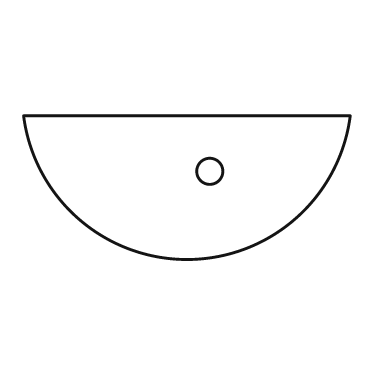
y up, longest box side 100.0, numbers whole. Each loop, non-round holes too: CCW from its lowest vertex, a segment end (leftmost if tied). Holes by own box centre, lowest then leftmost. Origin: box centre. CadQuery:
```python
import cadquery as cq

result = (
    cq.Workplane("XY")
    .moveTo(-50.0, 22.0)
    .threePointArc((0.0, -22.0), (50.0, 22.0))
    .close()
    .moveTo(7.0, 5.0)
    .circle(4.0)
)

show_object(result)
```